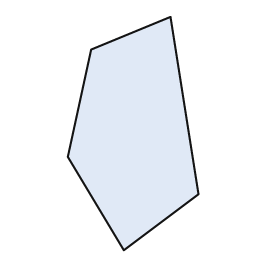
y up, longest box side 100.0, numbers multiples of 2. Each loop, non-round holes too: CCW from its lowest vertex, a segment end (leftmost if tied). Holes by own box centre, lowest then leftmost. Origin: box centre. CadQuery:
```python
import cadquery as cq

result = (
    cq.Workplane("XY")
    .moveTo(-4.0, -50.0)
    .lineTo(28.0, -26.0)
    .lineTo(16.0, 50.0)
    .lineTo(-18.0, 36.0)
    .lineTo(-28.0, -10.0)
    .close()
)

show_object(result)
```